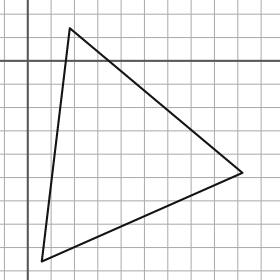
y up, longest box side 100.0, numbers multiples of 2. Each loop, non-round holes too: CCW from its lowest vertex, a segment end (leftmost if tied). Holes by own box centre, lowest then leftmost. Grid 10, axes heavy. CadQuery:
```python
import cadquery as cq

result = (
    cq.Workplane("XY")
    .moveTo(6.0, -86.0)
    .lineTo(92.0, -48.0)
    .lineTo(18.0, 14.0)
    .close()
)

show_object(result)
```